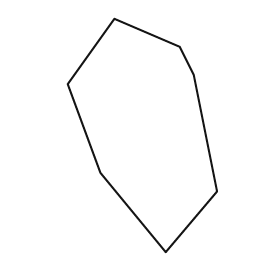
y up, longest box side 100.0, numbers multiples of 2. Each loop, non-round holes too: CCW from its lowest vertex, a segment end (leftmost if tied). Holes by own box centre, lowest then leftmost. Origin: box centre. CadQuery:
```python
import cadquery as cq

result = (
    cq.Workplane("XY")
    .moveTo(10.0, -50.0)
    .lineTo(32.0, -24.0)
    .lineTo(22.0, 26.0)
    .lineTo(16.0, 38.0)
    .lineTo(-12.0, 50.0)
    .lineTo(-32.0, 22.0)
    .lineTo(-18.0, -16.0)
    .close()
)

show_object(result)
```